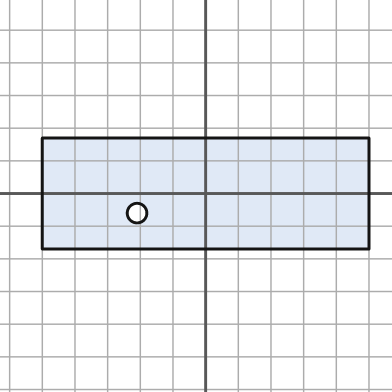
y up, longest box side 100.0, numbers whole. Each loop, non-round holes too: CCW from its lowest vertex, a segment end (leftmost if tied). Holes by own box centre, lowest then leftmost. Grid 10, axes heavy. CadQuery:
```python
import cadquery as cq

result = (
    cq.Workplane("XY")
    .moveTo(-50.0, -17.0)
    .lineTo(50.0, -17.0)
    .lineTo(50.0, 17.0)
    .lineTo(-50.0, 17.0)
    .close()
    .moveTo(-21.0, -6.0)
    .circle(3.0)
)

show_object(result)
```